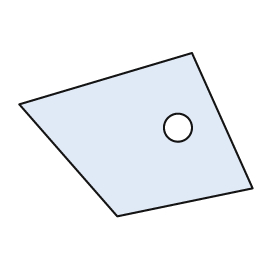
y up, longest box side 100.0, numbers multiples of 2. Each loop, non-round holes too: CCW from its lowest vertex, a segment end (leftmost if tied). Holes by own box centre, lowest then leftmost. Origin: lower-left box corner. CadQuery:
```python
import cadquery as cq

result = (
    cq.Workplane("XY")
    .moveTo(42.0, 0.0)
    .lineTo(100.0, 12.0)
    .lineTo(74.0, 70.0)
    .lineTo(0.0, 48.0)
    .close()
    .moveTo(68.0, 38.0)
    .circle(6.0)
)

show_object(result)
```